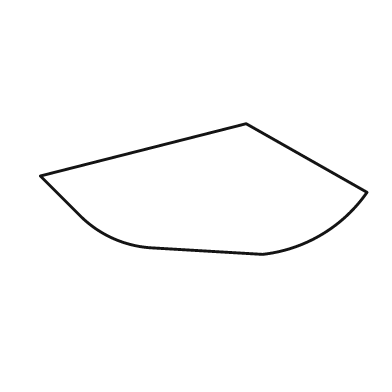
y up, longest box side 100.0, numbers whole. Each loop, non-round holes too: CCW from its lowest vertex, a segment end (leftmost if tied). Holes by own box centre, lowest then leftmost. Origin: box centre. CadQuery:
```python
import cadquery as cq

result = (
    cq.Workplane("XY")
    .moveTo(18.0, -20.0)
    .threePointArc((36.0, -14.0), (50.0, -1.0))
    .lineTo(13.0, 20.0)
    .lineTo(-50.0, 4.0)
    .lineTo(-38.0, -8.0)
    .threePointArc((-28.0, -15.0), (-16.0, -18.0))
    .close()
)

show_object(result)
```